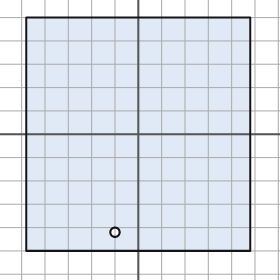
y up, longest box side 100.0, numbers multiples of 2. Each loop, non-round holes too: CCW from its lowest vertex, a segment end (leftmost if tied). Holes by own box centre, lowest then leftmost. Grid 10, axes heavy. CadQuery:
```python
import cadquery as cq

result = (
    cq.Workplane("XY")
    .moveTo(-48.0, -50.0)
    .lineTo(48.0, -50.0)
    .lineTo(48.0, 50.0)
    .lineTo(-48.0, 50.0)
    .close()
    .moveTo(-10.0, -42.0)
    .circle(2.0)
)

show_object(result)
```